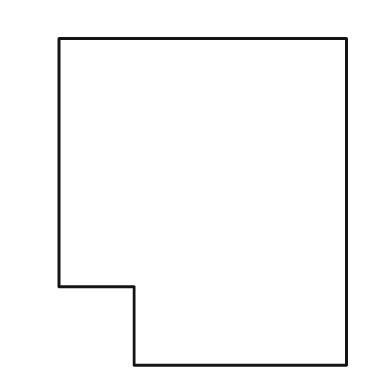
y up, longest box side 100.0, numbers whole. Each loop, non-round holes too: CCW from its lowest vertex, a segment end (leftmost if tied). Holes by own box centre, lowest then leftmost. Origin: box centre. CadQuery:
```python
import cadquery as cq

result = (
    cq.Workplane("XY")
    .moveTo(-21.0, -50.0)
    .lineTo(44.0, -50.0)
    .lineTo(44.0, 50.0)
    .lineTo(-44.0, 50.0)
    .lineTo(-44.0, -26.0)
    .lineTo(-21.0, -26.0)
    .close()
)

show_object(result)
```